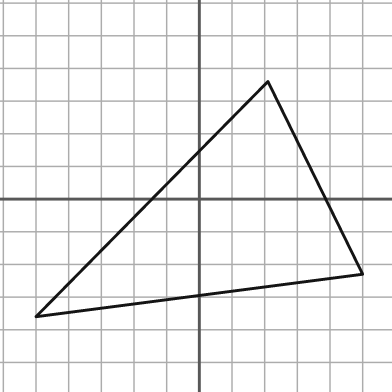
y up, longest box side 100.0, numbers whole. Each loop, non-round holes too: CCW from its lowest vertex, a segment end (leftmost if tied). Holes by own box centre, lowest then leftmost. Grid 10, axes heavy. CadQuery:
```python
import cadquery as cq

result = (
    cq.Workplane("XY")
    .moveTo(-50.0, -36.0)
    .lineTo(50.0, -23.0)
    .lineTo(21.0, 36.0)
    .close()
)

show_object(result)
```